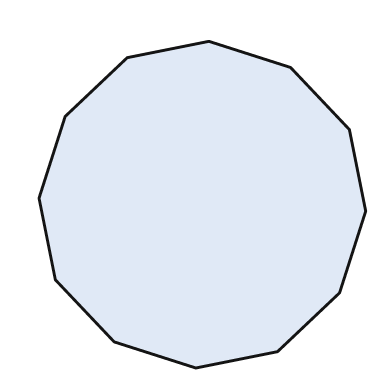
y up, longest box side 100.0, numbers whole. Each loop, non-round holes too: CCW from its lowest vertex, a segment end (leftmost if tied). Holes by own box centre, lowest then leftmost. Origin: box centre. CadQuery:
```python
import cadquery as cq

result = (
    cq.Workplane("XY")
    .moveTo(-2.0, -50.0)
    .lineTo(23.0, -45.0)
    .lineTo(42.0, -27.0)
    .lineTo(50.0, -2.0)
    .lineTo(45.0, 23.0)
    .lineTo(27.0, 42.0)
    .lineTo(2.0, 50.0)
    .lineTo(-23.0, 45.0)
    .lineTo(-42.0, 27.0)
    .lineTo(-50.0, 2.0)
    .lineTo(-45.0, -23.0)
    .lineTo(-27.0, -42.0)
    .close()
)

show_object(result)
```